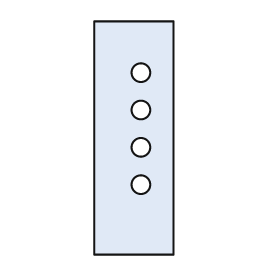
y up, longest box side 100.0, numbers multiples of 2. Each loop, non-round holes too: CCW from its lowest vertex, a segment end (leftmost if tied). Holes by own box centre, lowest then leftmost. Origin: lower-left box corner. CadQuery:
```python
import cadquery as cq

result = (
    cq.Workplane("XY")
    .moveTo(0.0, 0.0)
    .lineTo(34.0, 0.0)
    .lineTo(34.0, 100.0)
    .lineTo(0.0, 100.0)
    .close()
    .moveTo(20.0, 30.0)
    .circle(4.0)
    .moveTo(20.0, 46.0)
    .circle(4.0)
    .moveTo(20.0, 62.0)
    .circle(4.0)
    .moveTo(20.0, 78.0)
    .circle(4.0)
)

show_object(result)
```